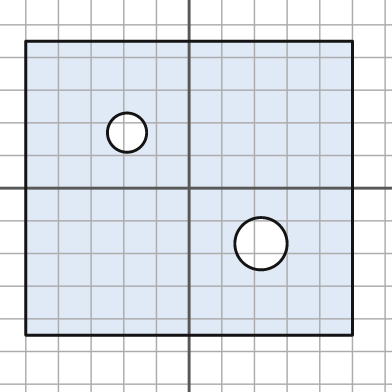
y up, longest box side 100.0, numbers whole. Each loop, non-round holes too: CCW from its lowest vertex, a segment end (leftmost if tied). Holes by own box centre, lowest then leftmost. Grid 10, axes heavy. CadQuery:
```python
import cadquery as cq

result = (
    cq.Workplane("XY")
    .moveTo(-50.0, -45.0)
    .lineTo(50.0, -45.0)
    .lineTo(50.0, 45.0)
    .lineTo(-50.0, 45.0)
    .close()
    .moveTo(22.0, -17.0)
    .circle(8.0)
    .moveTo(-19.0, 17.0)
    .circle(6.0)
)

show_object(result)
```